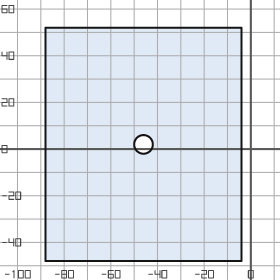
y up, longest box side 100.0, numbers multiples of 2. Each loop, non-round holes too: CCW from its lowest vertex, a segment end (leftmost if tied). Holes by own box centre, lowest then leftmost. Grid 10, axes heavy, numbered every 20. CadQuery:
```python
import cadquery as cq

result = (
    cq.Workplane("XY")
    .moveTo(-88.0, -48.0)
    .lineTo(-4.0, -48.0)
    .lineTo(-4.0, 52.0)
    .lineTo(-88.0, 52.0)
    .close()
    .moveTo(-46.0, 2.0)
    .circle(4.0)
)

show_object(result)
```